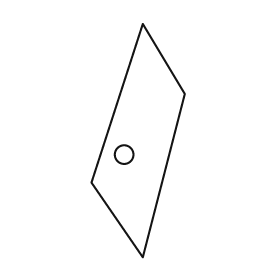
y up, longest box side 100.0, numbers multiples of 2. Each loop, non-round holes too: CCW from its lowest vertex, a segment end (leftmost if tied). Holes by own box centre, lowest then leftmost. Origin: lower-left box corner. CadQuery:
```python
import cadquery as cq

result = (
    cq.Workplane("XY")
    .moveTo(22.0, 0.0)
    .lineTo(40.0, 70.0)
    .lineTo(22.0, 100.0)
    .lineTo(0.0, 32.0)
    .close()
    .moveTo(14.0, 44.0)
    .circle(4.0)
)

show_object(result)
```